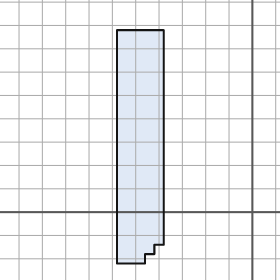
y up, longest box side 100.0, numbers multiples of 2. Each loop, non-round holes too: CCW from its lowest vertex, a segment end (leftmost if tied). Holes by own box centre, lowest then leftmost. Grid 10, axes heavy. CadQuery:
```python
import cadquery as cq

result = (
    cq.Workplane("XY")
    .moveTo(-58.0, -22.0)
    .lineTo(-46.0, -22.0)
    .lineTo(-46.0, -18.0)
    .lineTo(-42.0, -18.0)
    .lineTo(-42.0, -14.0)
    .lineTo(-38.0, -14.0)
    .lineTo(-38.0, 78.0)
    .lineTo(-58.0, 78.0)
    .close()
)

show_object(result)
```